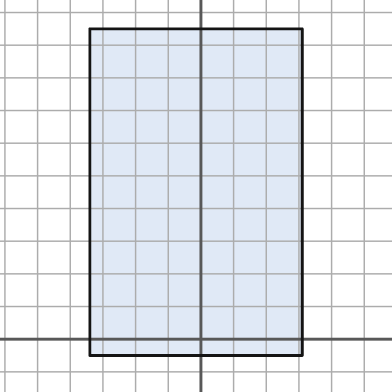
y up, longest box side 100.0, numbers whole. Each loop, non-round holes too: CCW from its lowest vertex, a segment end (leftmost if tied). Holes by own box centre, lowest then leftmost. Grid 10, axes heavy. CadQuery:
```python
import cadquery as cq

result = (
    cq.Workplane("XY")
    .moveTo(-34.0, -5.0)
    .lineTo(31.0, -5.0)
    .lineTo(31.0, 95.0)
    .lineTo(-34.0, 95.0)
    .close()
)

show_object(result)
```